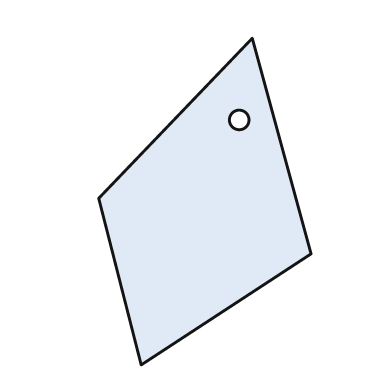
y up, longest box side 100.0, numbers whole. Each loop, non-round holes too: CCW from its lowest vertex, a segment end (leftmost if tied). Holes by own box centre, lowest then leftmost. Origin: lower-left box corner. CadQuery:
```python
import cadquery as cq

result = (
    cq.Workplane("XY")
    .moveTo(13.0, 0.0)
    .lineTo(65.0, 34.0)
    .lineTo(47.0, 100.0)
    .lineTo(0.0, 51.0)
    .close()
    .moveTo(43.0, 75.0)
    .circle(3.0)
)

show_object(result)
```